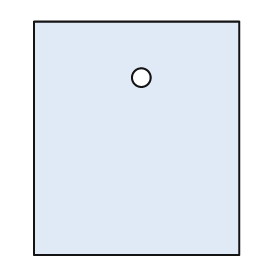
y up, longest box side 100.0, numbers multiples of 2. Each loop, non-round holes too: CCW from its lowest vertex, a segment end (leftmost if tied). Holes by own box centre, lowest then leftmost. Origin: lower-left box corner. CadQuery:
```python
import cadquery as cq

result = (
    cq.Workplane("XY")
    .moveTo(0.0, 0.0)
    .lineTo(88.0, 0.0)
    .lineTo(88.0, 100.0)
    .lineTo(0.0, 100.0)
    .close()
    .moveTo(46.0, 76.0)
    .circle(4.0)
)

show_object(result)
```